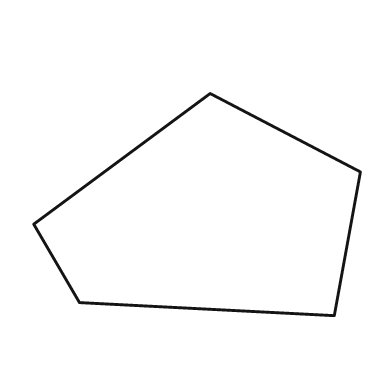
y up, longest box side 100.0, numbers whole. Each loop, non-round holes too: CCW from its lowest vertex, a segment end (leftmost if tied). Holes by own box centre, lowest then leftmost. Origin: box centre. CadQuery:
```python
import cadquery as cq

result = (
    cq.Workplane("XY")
    .moveTo(42.0, -34.0)
    .lineTo(50.0, 10.0)
    .lineTo(4.0, 34.0)
    .lineTo(-50.0, -6.0)
    .lineTo(-36.0, -30.0)
    .close()
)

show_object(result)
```